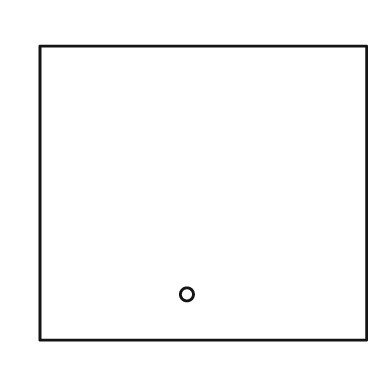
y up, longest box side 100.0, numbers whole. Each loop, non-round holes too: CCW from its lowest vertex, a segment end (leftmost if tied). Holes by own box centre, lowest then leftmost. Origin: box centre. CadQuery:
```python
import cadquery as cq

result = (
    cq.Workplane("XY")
    .moveTo(-50.0, -45.0)
    .lineTo(50.0, -45.0)
    .lineTo(50.0, 45.0)
    .lineTo(-50.0, 45.0)
    .close()
    .moveTo(-5.0, -31.0)
    .circle(2.0)
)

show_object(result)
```